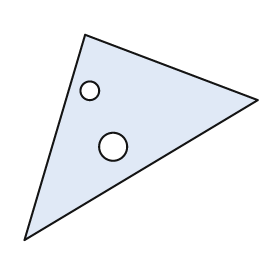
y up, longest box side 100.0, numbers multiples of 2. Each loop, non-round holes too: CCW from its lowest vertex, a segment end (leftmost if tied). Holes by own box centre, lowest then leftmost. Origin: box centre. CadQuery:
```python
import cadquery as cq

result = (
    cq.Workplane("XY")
    .moveTo(-50.0, -44.0)
    .lineTo(50.0, 16.0)
    .lineTo(-24.0, 44.0)
    .close()
    .moveTo(-12.0, -4.0)
    .circle(6.0)
    .moveTo(-22.0, 20.0)
    .circle(4.0)
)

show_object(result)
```